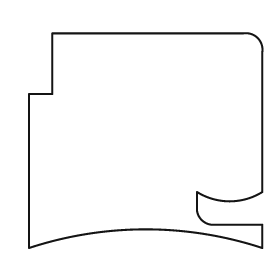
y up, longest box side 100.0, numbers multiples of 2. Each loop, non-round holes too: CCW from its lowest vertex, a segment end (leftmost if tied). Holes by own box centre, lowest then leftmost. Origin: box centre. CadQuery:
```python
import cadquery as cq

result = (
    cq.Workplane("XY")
    .moveTo(-50.0, -46.0)
    .threePointArc((0.0, -38.0), (50.0, -46.0))
    .lineTo(50.0, -36.0)
    .lineTo(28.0, -36.0)
    .threePointArc((24.0, -34.0), (22.0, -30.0))
    .lineTo(22.0, -22.0)
    .threePointArc((36.0, -26.0), (50.0, -22.0))
    .lineTo(50.0, 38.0)
    .threePointArc((48.0, 44.0), (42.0, 46.0))
    .lineTo(-40.0, 46.0)
    .lineTo(-40.0, 20.0)
    .lineTo(-50.0, 20.0)
    .close()
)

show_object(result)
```